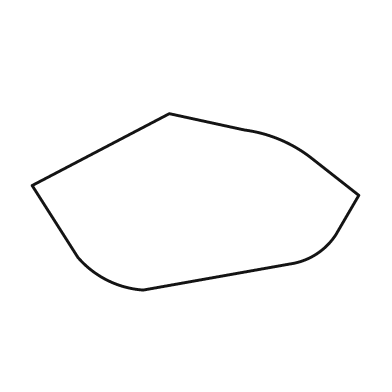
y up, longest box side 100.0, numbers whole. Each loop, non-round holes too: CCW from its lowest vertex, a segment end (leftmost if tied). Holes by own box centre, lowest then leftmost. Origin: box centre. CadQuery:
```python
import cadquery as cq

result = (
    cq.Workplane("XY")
    .moveTo(-16.0, -27.0)
    .lineTo(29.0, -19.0)
    .threePointArc((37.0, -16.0), (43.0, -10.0))
    .lineTo(50.0, 2.0)
    .lineTo(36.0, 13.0)
    .threePointArc((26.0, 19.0), (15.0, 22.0))
    .lineTo(-8.0, 27.0)
    .lineTo(-50.0, 5.0)
    .lineTo(-36.0, -17.0)
    .threePointArc((-27.0, -24.0), (-16.0, -27.0))
    .close()
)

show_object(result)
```